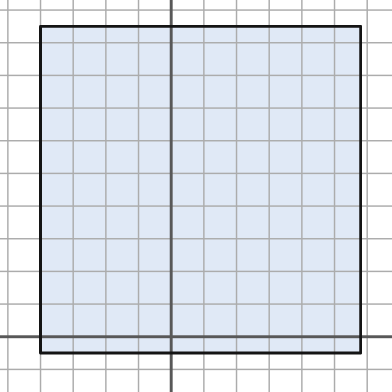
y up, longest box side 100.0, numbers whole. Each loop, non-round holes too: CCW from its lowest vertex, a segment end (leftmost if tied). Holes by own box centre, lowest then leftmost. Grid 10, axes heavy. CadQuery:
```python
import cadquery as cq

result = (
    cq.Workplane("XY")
    .moveTo(-40.0, -5.0)
    .lineTo(58.0, -5.0)
    .lineTo(58.0, 95.0)
    .lineTo(-40.0, 95.0)
    .close()
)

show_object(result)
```